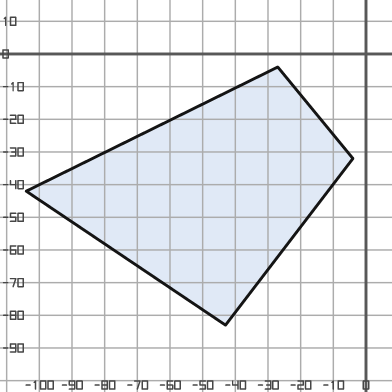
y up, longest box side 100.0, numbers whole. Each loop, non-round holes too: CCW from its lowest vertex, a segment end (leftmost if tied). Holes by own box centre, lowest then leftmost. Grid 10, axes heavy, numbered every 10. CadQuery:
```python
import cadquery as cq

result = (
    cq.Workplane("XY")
    .moveTo(-43.0, -83.0)
    .lineTo(-4.0, -32.0)
    .lineTo(-27.0, -4.0)
    .lineTo(-104.0, -42.0)
    .close()
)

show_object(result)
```